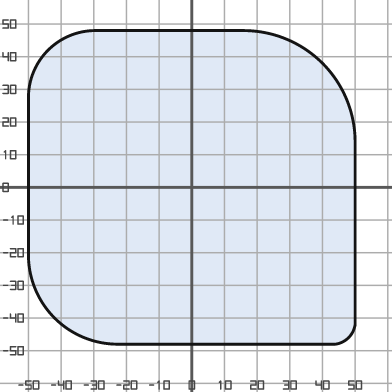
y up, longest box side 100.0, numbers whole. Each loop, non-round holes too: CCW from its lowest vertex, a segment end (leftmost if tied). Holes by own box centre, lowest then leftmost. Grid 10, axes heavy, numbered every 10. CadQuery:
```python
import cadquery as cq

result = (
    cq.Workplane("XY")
    .moveTo(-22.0, -48.0)
    .lineTo(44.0, -48.0)
    .threePointArc((48.0, -46.0), (50.0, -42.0))
    .lineTo(50.0, 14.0)
    .threePointArc((40.0, 38.0), (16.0, 48.0))
    .lineTo(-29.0, 48.0)
    .threePointArc((-44.0, 42.0), (-50.0, 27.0))
    .lineTo(-50.0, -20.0)
    .threePointArc((-42.0, -40.0), (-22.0, -48.0))
    .close()
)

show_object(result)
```